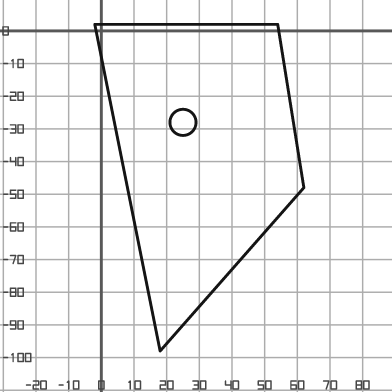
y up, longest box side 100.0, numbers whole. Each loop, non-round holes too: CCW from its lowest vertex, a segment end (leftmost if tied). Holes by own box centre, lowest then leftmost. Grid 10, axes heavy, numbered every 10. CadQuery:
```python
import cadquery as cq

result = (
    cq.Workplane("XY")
    .moveTo(18.0, -98.0)
    .lineTo(62.0, -48.0)
    .lineTo(54.0, 2.0)
    .lineTo(-2.0, 2.0)
    .close()
    .moveTo(25.0, -28.0)
    .circle(4.0)
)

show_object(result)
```